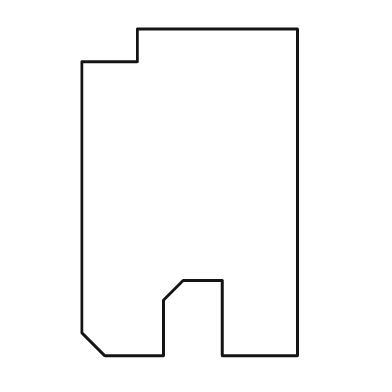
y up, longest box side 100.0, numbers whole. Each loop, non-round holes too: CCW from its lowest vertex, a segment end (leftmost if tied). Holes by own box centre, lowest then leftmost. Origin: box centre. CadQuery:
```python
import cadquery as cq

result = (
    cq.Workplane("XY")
    .moveTo(-26.0, -50.0)
    .lineTo(-8.0, -50.0)
    .lineTo(-8.0, -33.0)
    .lineTo(-2.0, -27.0)
    .lineTo(10.0, -27.0)
    .lineTo(10.0, -50.0)
    .lineTo(33.0, -50.0)
    .lineTo(33.0, 50.0)
    .lineTo(-16.0, 50.0)
    .lineTo(-16.0, 40.0)
    .lineTo(-33.0, 40.0)
    .lineTo(-33.0, -43.0)
    .close()
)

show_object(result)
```